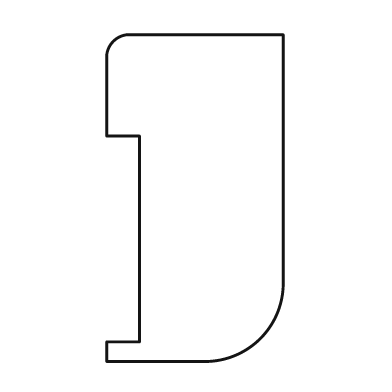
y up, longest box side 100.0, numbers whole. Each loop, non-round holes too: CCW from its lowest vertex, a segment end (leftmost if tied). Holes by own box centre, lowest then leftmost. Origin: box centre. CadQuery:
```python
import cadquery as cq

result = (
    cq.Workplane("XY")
    .moveTo(-27.0, -50.0)
    .lineTo(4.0, -50.0)
    .threePointArc((20.0, -43.0), (27.0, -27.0))
    .lineTo(27.0, 50.0)
    .lineTo(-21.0, 50.0)
    .threePointArc((-25.0, 48.0), (-27.0, 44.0))
    .lineTo(-27.0, 19.0)
    .lineTo(-17.0, 19.0)
    .lineTo(-17.0, -44.0)
    .lineTo(-27.0, -44.0)
    .close()
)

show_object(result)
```